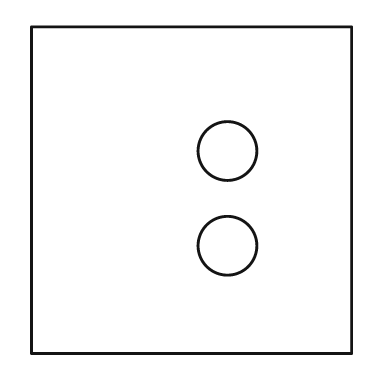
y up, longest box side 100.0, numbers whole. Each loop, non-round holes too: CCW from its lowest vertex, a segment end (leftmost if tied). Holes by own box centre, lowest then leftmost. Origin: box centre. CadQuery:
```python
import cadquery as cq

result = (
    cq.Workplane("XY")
    .moveTo(-49.0, -50.0)
    .lineTo(49.0, -50.0)
    .lineTo(49.0, 50.0)
    .lineTo(-49.0, 50.0)
    .close()
    .moveTo(11.0, -17.0)
    .circle(9.0)
    .moveTo(11.0, 12.0)
    .circle(9.0)
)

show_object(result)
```